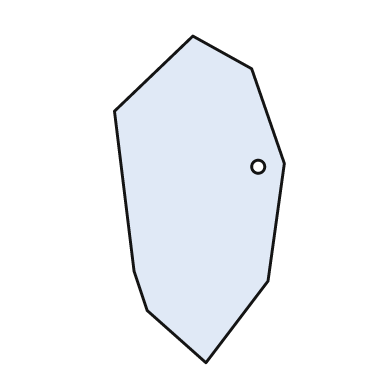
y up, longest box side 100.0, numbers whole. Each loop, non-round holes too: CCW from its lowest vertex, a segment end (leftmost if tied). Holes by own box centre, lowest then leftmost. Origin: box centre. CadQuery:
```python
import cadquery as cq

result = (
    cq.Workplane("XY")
    .moveTo(2.0, -50.0)
    .lineTo(21.0, -25.0)
    .lineTo(26.0, 11.0)
    .lineTo(16.0, 40.0)
    .lineTo(-2.0, 50.0)
    .lineTo(-26.0, 27.0)
    .lineTo(-20.0, -22.0)
    .lineTo(-16.0, -34.0)
    .close()
    .moveTo(18.0, 10.0)
    .circle(2.0)
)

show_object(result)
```